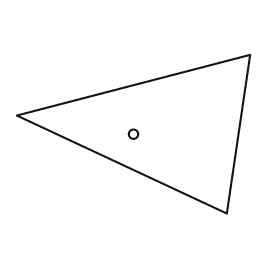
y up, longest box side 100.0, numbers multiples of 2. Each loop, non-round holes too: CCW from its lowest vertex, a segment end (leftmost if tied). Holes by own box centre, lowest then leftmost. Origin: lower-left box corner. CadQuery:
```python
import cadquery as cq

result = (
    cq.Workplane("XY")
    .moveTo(90.0, 0.0)
    .lineTo(100.0, 68.0)
    .lineTo(0.0, 42.0)
    .close()
    .moveTo(50.0, 34.0)
    .circle(2.0)
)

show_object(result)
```